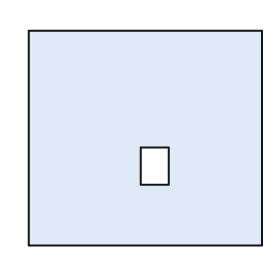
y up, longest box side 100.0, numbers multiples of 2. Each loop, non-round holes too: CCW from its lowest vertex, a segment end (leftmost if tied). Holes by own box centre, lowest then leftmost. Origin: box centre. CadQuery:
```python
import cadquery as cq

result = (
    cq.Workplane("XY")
    .moveTo(-50.0, -46.0)
    .lineTo(50.0, -46.0)
    .lineTo(50.0, 46.0)
    .lineTo(-50.0, 46.0)
    .close()
    .moveTo(-2.0, -20.0)
    .lineTo(10.0, -20.0)
    .lineTo(10.0, -4.0)
    .lineTo(-2.0, -4.0)
    .close()
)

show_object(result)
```